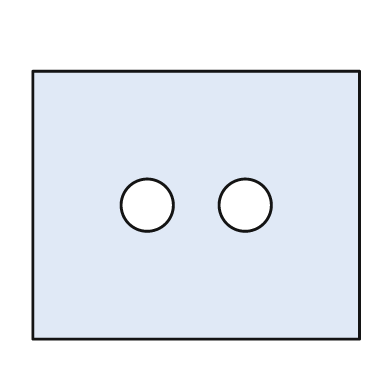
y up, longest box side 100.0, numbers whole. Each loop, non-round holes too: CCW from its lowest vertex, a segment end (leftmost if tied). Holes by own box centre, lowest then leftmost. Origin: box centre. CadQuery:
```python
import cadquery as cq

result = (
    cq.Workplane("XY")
    .moveTo(-50.0, -41.0)
    .lineTo(50.0, -41.0)
    .lineTo(50.0, 41.0)
    .lineTo(-50.0, 41.0)
    .close()
    .moveTo(-15.0, 0.0)
    .circle(8.0)
    .moveTo(15.0, 0.0)
    .circle(8.0)
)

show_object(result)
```